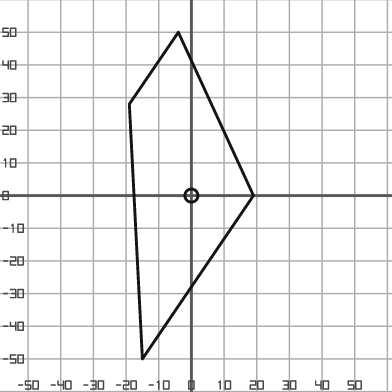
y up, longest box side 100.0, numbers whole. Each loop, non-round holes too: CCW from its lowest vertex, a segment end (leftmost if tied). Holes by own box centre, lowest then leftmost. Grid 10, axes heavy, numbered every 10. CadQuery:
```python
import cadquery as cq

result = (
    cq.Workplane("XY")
    .moveTo(-15.0, -50.0)
    .lineTo(19.0, 0.0)
    .lineTo(-4.0, 50.0)
    .lineTo(-19.0, 28.0)
    .close()
    .moveTo(0.0, 0.0)
    .circle(2.0)
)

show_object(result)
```